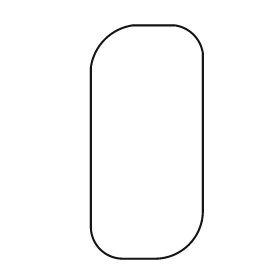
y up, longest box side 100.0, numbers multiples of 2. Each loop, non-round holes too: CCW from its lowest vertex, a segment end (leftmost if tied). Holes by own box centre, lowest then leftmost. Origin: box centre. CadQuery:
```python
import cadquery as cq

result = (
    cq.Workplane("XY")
    .moveTo(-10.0, -50.0)
    .lineTo(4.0, -50.0)
    .threePointArc((18.0, -44.0), (24.0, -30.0))
    .lineTo(24.0, 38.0)
    .threePointArc((20.0, 46.0), (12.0, 50.0))
    .lineTo(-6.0, 50.0)
    .threePointArc((-18.0, 44.0), (-24.0, 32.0))
    .lineTo(-24.0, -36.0)
    .threePointArc((-20.0, -46.0), (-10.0, -50.0))
    .close()
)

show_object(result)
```